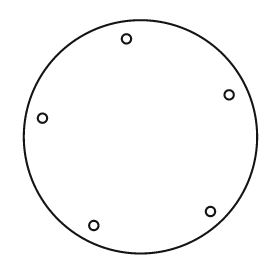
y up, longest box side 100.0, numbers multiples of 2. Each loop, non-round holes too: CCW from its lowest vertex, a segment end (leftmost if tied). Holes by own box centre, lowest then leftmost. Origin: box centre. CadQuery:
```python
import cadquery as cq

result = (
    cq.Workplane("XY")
    .moveTo(0.0, 0.0)
    .circle(50.0)
    .moveTo(-20.0, -38.0)
    .circle(2.0)
    .moveTo(30.0, -32.0)
    .circle(2.0)
    .moveTo(-42.0, 8.0)
    .circle(2.0)
    .moveTo(38.0, 18.0)
    .circle(2.0)
    .moveTo(-6.0, 42.0)
    .circle(2.0)
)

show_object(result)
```